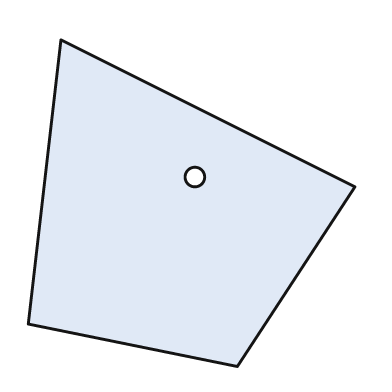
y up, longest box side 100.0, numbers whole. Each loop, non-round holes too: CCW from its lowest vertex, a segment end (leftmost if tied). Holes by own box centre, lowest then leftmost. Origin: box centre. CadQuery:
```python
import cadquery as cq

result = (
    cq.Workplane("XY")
    .moveTo(14.0, -50.0)
    .lineTo(50.0, 5.0)
    .lineTo(-40.0, 50.0)
    .lineTo(-50.0, -37.0)
    .close()
    .moveTo(1.0, 8.0)
    .circle(3.0)
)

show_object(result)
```